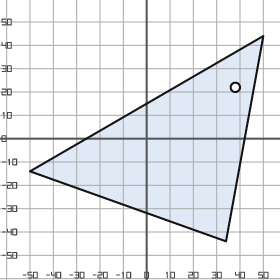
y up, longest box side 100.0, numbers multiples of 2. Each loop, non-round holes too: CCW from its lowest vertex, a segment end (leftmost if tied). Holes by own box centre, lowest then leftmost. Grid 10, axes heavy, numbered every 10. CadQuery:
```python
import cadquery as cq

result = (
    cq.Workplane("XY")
    .moveTo(34.0, -44.0)
    .lineTo(50.0, 44.0)
    .lineTo(-50.0, -14.0)
    .close()
    .moveTo(38.0, 22.0)
    .circle(2.0)
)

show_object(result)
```